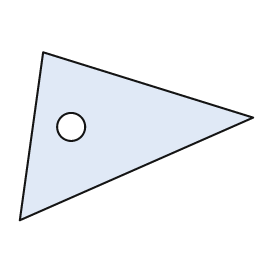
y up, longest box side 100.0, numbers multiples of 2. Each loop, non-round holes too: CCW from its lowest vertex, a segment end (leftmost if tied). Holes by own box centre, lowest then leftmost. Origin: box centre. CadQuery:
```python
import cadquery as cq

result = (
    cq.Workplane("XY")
    .moveTo(-50.0, -36.0)
    .lineTo(50.0, 8.0)
    .lineTo(-40.0, 36.0)
    .close()
    .moveTo(-28.0, 4.0)
    .circle(6.0)
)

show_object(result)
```